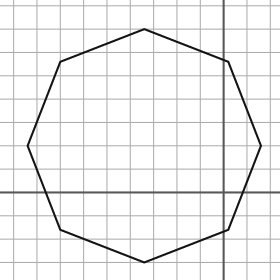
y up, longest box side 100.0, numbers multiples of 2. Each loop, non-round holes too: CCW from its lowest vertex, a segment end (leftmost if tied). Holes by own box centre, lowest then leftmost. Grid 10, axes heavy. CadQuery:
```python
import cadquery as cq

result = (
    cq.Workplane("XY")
    .moveTo(-34.0, -30.0)
    .lineTo(2.0, -16.0)
    .lineTo(16.0, 20.0)
    .lineTo(2.0, 56.0)
    .lineTo(-34.0, 70.0)
    .lineTo(-70.0, 56.0)
    .lineTo(-84.0, 20.0)
    .lineTo(-70.0, -16.0)
    .close()
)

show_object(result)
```